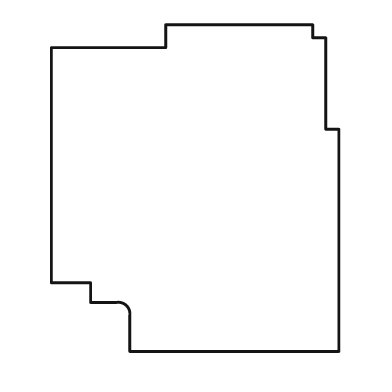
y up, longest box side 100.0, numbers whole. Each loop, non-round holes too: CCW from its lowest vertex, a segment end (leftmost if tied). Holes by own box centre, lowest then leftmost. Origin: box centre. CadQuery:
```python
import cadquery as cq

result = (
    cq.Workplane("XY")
    .moveTo(-20.0, -50.0)
    .lineTo(44.0, -50.0)
    .lineTo(44.0, 18.0)
    .lineTo(40.0, 18.0)
    .lineTo(40.0, 46.0)
    .lineTo(36.0, 46.0)
    .lineTo(36.0, 50.0)
    .lineTo(-9.0, 50.0)
    .lineTo(-9.0, 43.0)
    .lineTo(-44.0, 43.0)
    .lineTo(-44.0, -29.0)
    .lineTo(-32.0, -29.0)
    .lineTo(-32.0, -35.0)
    .lineTo(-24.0, -35.0)
    .threePointArc((-21.0, -36.0), (-20.0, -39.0))
    .close()
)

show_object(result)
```